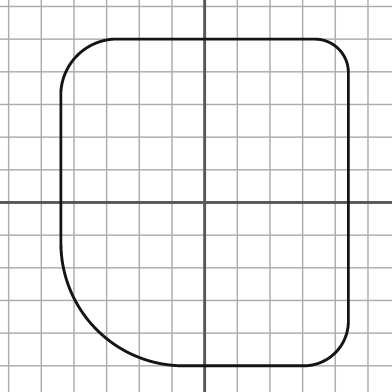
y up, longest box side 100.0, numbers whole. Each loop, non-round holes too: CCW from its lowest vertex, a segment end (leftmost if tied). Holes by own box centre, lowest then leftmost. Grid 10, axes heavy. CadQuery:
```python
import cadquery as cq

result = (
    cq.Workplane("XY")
    .moveTo(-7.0, -50.0)
    .lineTo(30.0, -50.0)
    .threePointArc((40.0, -46.0), (44.0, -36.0))
    .lineTo(44.0, 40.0)
    .threePointArc((41.0, 47.0), (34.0, 50.0))
    .lineTo(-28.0, 50.0)
    .threePointArc((-39.0, 45.0), (-44.0, 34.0))
    .lineTo(-44.0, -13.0)
    .threePointArc((-33.0, -39.0), (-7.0, -50.0))
    .close()
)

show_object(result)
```